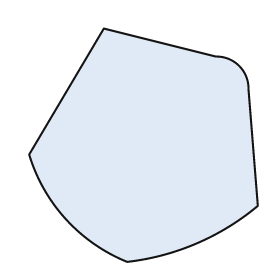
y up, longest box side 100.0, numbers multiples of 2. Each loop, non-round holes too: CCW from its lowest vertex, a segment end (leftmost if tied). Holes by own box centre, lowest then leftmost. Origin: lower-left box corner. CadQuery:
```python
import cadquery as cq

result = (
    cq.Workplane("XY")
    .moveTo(42.0, 0.0)
    .threePointArc((72.0, 8.0), (98.0, 24.0))
    .lineTo(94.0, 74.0)
    .threePointArc((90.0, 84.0), (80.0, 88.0))
    .lineTo(32.0, 100.0)
    .lineTo(0.0, 46.0)
    .threePointArc((16.0, 18.0), (42.0, 0.0))
    .close()
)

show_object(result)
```